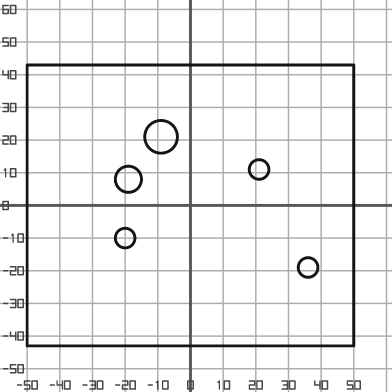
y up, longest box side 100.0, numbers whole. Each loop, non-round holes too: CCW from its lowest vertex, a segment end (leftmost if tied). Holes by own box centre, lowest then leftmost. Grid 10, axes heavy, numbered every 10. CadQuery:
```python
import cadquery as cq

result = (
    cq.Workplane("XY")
    .moveTo(-50.0, -43.0)
    .lineTo(50.0, -43.0)
    .lineTo(50.0, 43.0)
    .lineTo(-50.0, 43.0)
    .close()
    .moveTo(36.0, -19.0)
    .circle(3.0)
    .moveTo(-20.0, -10.0)
    .circle(3.0)
    .moveTo(-19.0, 8.0)
    .circle(4.0)
    .moveTo(21.0, 11.0)
    .circle(3.0)
    .moveTo(-9.0, 21.0)
    .circle(5.0)
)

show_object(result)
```